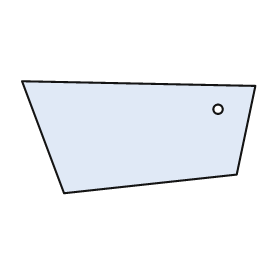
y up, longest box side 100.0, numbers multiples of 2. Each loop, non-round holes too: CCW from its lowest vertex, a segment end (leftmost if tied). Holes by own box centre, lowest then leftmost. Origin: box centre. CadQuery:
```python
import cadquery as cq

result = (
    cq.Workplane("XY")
    .moveTo(-32.0, -24.0)
    .lineTo(42.0, -16.0)
    .lineTo(50.0, 22.0)
    .lineTo(-50.0, 24.0)
    .close()
    .moveTo(34.0, 12.0)
    .circle(2.0)
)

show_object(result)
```